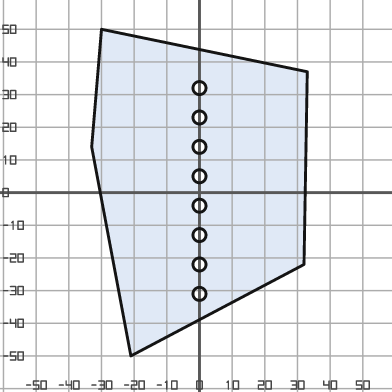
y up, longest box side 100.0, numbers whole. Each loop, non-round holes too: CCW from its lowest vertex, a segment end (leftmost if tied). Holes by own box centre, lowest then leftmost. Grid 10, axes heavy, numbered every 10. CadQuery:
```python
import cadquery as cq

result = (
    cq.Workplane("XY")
    .moveTo(-21.0, -50.0)
    .lineTo(32.0, -22.0)
    .lineTo(33.0, 37.0)
    .lineTo(-30.0, 50.0)
    .lineTo(-33.0, 14.0)
    .close()
    .moveTo(0.0, -31.0)
    .circle(2.0)
    .moveTo(0.0, -22.0)
    .circle(2.0)
    .moveTo(0.0, -13.0)
    .circle(2.0)
    .moveTo(0.0, -4.0)
    .circle(2.0)
    .moveTo(0.0, 5.0)
    .circle(2.0)
    .moveTo(0.0, 14.0)
    .circle(2.0)
    .moveTo(0.0, 23.0)
    .circle(2.0)
    .moveTo(0.0, 32.0)
    .circle(2.0)
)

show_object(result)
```